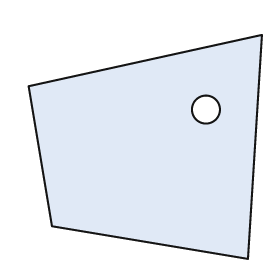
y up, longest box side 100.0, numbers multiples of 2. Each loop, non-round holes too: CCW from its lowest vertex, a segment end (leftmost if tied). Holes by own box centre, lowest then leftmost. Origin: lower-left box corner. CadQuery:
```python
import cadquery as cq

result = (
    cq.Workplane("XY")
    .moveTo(94.0, 0.0)
    .lineTo(100.0, 96.0)
    .lineTo(0.0, 74.0)
    .lineTo(10.0, 14.0)
    .close()
    .moveTo(76.0, 64.0)
    .circle(6.0)
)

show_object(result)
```